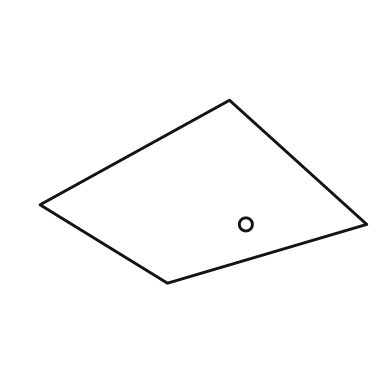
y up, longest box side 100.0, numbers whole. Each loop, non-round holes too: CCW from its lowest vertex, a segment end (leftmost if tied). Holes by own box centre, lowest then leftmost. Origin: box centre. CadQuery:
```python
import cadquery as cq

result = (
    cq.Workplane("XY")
    .moveTo(-11.0, -28.0)
    .lineTo(50.0, -10.0)
    .lineTo(8.0, 28.0)
    .lineTo(-50.0, -4.0)
    .close()
    .moveTo(13.0, -10.0)
    .circle(2.0)
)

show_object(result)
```